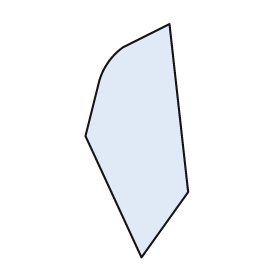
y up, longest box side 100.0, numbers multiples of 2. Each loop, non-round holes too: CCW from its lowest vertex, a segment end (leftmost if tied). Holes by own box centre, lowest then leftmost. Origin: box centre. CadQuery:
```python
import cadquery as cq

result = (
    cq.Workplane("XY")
    .moveTo(2.0, -50.0)
    .lineTo(22.0, -22.0)
    .lineTo(14.0, 50.0)
    .lineTo(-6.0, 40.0)
    .threePointArc((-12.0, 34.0), (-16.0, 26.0))
    .lineTo(-22.0, 2.0)
    .close()
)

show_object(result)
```